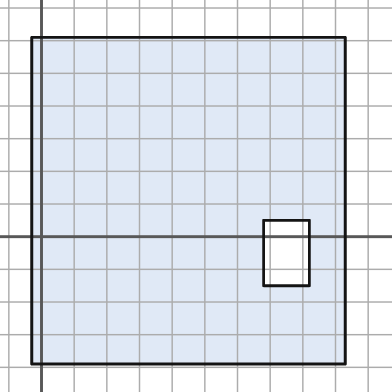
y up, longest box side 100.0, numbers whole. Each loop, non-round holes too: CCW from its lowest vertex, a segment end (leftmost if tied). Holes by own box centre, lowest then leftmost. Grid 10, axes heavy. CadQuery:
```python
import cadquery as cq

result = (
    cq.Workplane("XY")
    .moveTo(-3.0, -39.0)
    .lineTo(93.0, -39.0)
    .lineTo(93.0, 61.0)
    .lineTo(-3.0, 61.0)
    .close()
    .moveTo(68.0, -15.0)
    .lineTo(82.0, -15.0)
    .lineTo(82.0, 5.0)
    .lineTo(68.0, 5.0)
    .close()
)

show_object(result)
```